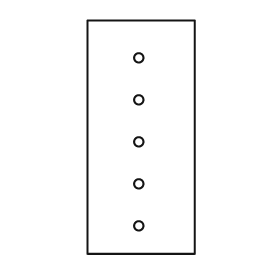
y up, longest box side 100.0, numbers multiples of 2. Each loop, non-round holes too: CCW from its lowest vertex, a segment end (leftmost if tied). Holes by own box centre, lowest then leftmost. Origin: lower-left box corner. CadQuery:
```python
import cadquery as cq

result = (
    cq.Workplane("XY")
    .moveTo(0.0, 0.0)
    .lineTo(46.0, 0.0)
    .lineTo(46.0, 100.0)
    .lineTo(0.0, 100.0)
    .close()
    .moveTo(22.0, 12.0)
    .circle(2.0)
    .moveTo(22.0, 30.0)
    .circle(2.0)
    .moveTo(22.0, 48.0)
    .circle(2.0)
    .moveTo(22.0, 66.0)
    .circle(2.0)
    .moveTo(22.0, 84.0)
    .circle(2.0)
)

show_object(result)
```